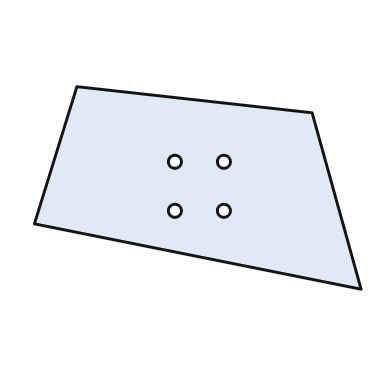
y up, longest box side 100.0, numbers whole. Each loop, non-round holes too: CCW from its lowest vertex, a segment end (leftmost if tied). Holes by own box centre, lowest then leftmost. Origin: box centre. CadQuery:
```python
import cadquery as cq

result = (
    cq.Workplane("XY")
    .moveTo(50.0, -31.0)
    .lineTo(35.0, 23.0)
    .lineTo(-37.0, 31.0)
    .lineTo(-50.0, -11.0)
    .close()
    .moveTo(-7.0, -7.0)
    .circle(2.0)
    .moveTo(8.0, -7.0)
    .circle(2.0)
    .moveTo(-7.0, 8.0)
    .circle(2.0)
    .moveTo(8.0, 8.0)
    .circle(2.0)
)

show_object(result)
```